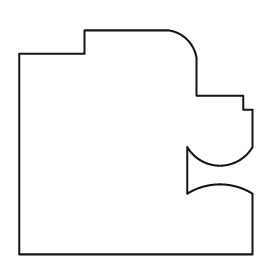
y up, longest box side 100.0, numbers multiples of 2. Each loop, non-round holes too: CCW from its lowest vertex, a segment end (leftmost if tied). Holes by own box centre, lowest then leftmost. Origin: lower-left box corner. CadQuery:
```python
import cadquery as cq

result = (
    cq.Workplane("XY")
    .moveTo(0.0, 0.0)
    .lineTo(100.0, 0.0)
    .lineTo(100.0, 26.0)
    .threePointArc((86.0, 30.0), (72.0, 26.0))
    .lineTo(72.0, 46.0)
    .threePointArc((86.0, 38.0), (100.0, 46.0))
    .lineTo(100.0, 62.0)
    .lineTo(96.0, 62.0)
    .lineTo(96.0, 68.0)
    .lineTo(76.0, 68.0)
    .lineTo(76.0, 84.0)
    .threePointArc((72.0, 92.0), (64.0, 96.0))
    .lineTo(28.0, 96.0)
    .lineTo(28.0, 86.0)
    .lineTo(0.0, 86.0)
    .close()
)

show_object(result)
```